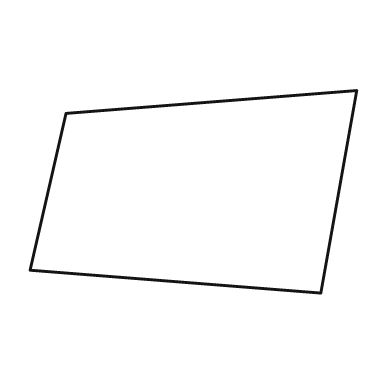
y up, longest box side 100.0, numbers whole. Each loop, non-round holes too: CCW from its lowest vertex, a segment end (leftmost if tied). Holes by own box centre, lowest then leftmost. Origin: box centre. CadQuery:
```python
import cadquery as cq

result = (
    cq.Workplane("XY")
    .moveTo(39.0, -31.0)
    .lineTo(50.0, 31.0)
    .lineTo(-39.0, 24.0)
    .lineTo(-50.0, -24.0)
    .close()
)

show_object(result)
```